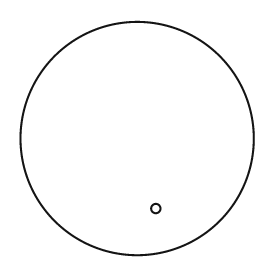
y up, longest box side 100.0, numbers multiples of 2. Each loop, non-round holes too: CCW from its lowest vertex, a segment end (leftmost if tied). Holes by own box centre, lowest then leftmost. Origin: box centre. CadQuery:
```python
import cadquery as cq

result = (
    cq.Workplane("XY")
    .moveTo(0.0, 0.0)
    .circle(50.0)
    .moveTo(8.0, -30.0)
    .circle(2.0)
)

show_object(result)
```